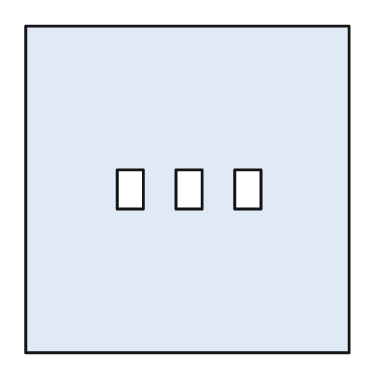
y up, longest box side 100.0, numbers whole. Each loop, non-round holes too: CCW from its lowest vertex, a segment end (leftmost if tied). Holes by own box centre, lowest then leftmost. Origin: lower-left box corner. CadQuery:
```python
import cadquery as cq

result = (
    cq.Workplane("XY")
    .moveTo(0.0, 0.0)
    .lineTo(99.0, 0.0)
    .lineTo(99.0, 100.0)
    .lineTo(0.0, 100.0)
    .close()
    .moveTo(28.0, 44.0)
    .lineTo(36.0, 44.0)
    .lineTo(36.0, 56.0)
    .lineTo(28.0, 56.0)
    .close()
    .moveTo(46.0, 44.0)
    .lineTo(54.0, 44.0)
    .lineTo(54.0, 56.0)
    .lineTo(46.0, 56.0)
    .close()
    .moveTo(64.0, 44.0)
    .lineTo(72.0, 44.0)
    .lineTo(72.0, 56.0)
    .lineTo(64.0, 56.0)
    .close()
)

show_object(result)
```